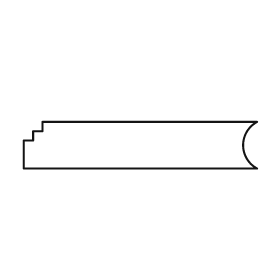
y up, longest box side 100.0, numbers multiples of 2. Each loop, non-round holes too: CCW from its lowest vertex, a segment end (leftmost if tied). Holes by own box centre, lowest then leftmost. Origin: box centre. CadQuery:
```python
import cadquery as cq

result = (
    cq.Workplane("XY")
    .moveTo(-50.0, -10.0)
    .lineTo(50.0, -10.0)
    .threePointArc((44.0, 0.0), (50.0, 10.0))
    .lineTo(-42.0, 10.0)
    .lineTo(-42.0, 6.0)
    .lineTo(-46.0, 6.0)
    .lineTo(-46.0, 2.0)
    .lineTo(-50.0, 2.0)
    .close()
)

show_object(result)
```